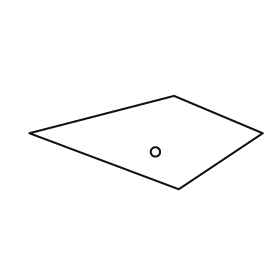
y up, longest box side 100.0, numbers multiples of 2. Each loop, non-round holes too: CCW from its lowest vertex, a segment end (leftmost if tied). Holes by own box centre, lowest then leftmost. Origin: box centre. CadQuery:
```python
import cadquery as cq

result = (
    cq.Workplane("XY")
    .moveTo(14.0, -20.0)
    .lineTo(50.0, 4.0)
    .lineTo(12.0, 20.0)
    .lineTo(-50.0, 4.0)
    .close()
    .moveTo(4.0, -4.0)
    .circle(2.0)
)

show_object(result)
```